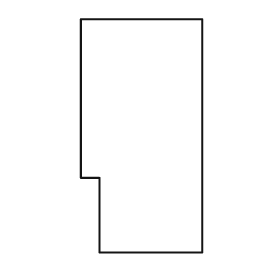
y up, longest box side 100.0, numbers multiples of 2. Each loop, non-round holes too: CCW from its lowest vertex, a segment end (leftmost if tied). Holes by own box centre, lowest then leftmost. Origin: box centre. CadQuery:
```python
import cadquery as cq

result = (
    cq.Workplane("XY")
    .moveTo(-18.0, -50.0)
    .lineTo(26.0, -50.0)
    .lineTo(26.0, 50.0)
    .lineTo(-26.0, 50.0)
    .lineTo(-26.0, -18.0)
    .lineTo(-18.0, -18.0)
    .close()
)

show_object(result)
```